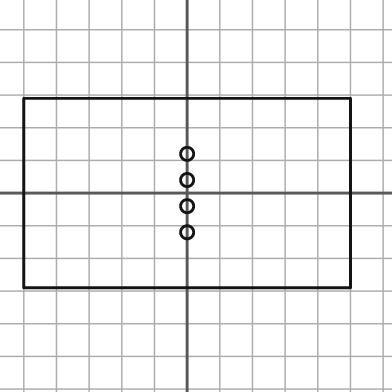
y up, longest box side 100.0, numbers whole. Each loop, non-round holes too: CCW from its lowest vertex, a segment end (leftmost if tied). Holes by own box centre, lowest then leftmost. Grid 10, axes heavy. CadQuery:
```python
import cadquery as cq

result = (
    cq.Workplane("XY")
    .moveTo(-50.0, -29.0)
    .lineTo(50.0, -29.0)
    .lineTo(50.0, 29.0)
    .lineTo(-50.0, 29.0)
    .close()
    .moveTo(0.0, -12.0)
    .circle(2.0)
    .moveTo(0.0, -4.0)
    .circle(2.0)
    .moveTo(0.0, 4.0)
    .circle(2.0)
    .moveTo(0.0, 12.0)
    .circle(2.0)
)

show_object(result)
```